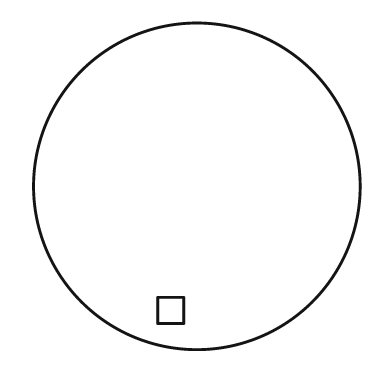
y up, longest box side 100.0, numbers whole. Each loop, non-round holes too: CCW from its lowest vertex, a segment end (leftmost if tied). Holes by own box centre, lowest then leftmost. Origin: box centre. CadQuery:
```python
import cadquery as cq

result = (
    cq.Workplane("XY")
    .moveTo(0.0, 0.0)
    .circle(50.0)
    .moveTo(-12.0, -42.0)
    .lineTo(-4.0, -42.0)
    .lineTo(-4.0, -34.0)
    .lineTo(-12.0, -34.0)
    .close()
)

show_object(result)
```